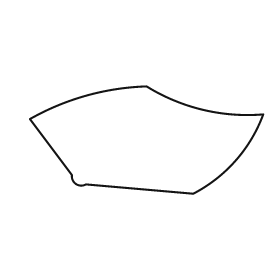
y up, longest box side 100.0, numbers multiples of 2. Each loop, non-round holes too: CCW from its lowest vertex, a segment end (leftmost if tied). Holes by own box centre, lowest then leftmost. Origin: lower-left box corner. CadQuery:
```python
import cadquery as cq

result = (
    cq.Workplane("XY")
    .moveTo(70.0, 0.0)
    .threePointArc((88.0, 14.0), (100.0, 34.0))
    .threePointArc((74.0, 36.0), (50.0, 46.0))
    .threePointArc((24.0, 42.0), (0.0, 32.0))
    .lineTo(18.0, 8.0)
    .threePointArc((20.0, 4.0), (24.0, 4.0))
    .close()
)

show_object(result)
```